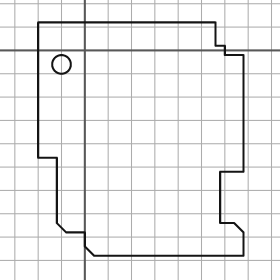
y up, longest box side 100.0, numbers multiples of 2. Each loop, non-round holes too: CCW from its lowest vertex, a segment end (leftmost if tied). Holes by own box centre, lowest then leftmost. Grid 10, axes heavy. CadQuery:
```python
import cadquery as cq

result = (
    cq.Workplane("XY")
    .moveTo(4.0, -88.0)
    .lineTo(68.0, -88.0)
    .lineTo(68.0, -78.0)
    .lineTo(64.0, -74.0)
    .lineTo(58.0, -74.0)
    .lineTo(58.0, -52.0)
    .lineTo(68.0, -52.0)
    .lineTo(68.0, -2.0)
    .lineTo(60.0, -2.0)
    .lineTo(60.0, 2.0)
    .lineTo(56.0, 2.0)
    .lineTo(56.0, 12.0)
    .lineTo(-20.0, 12.0)
    .lineTo(-20.0, -46.0)
    .lineTo(-12.0, -46.0)
    .lineTo(-12.0, -74.0)
    .lineTo(-8.0, -78.0)
    .lineTo(0.0, -78.0)
    .lineTo(0.0, -84.0)
    .close()
    .moveTo(-10.0, -6.0)
    .circle(4.0)
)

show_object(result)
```